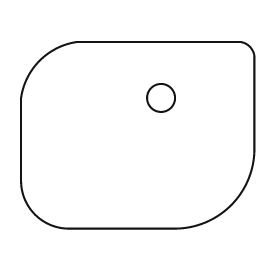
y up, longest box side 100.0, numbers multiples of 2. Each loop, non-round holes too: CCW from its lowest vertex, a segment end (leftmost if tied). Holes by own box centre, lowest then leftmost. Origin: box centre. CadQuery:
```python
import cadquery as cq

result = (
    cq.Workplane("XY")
    .moveTo(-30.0, -40.0)
    .lineTo(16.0, -40.0)
    .threePointArc((40.0, -30.0), (50.0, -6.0))
    .lineTo(50.0, 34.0)
    .threePointArc((48.0, 38.0), (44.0, 40.0))
    .lineTo(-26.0, 40.0)
    .threePointArc((-42.0, 32.0), (-50.0, 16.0))
    .lineTo(-50.0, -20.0)
    .threePointArc((-44.0, -34.0), (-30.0, -40.0))
    .close()
    .moveTo(10.0, 16.0)
    .circle(6.0)
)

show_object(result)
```